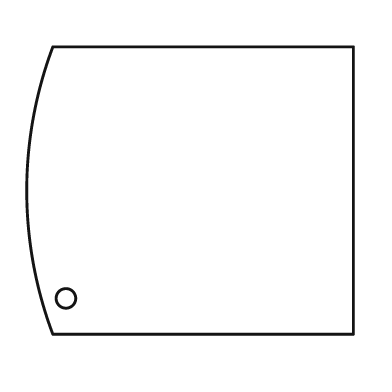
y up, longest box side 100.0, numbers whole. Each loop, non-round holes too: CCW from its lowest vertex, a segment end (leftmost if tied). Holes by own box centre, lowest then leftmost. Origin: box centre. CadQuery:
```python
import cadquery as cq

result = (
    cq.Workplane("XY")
    .moveTo(-42.0, -44.0)
    .lineTo(50.0, -44.0)
    .lineTo(50.0, 44.0)
    .lineTo(-42.0, 44.0)
    .threePointArc((-50.0, 0.0), (-42.0, -44.0))
    .close()
    .moveTo(-38.0, -33.0)
    .circle(3.0)
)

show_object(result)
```